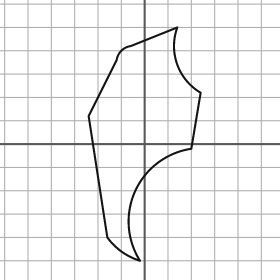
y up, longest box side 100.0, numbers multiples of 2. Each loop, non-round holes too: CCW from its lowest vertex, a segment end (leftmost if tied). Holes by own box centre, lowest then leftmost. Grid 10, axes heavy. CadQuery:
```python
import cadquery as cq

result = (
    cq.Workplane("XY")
    .moveTo(-2.0, -50.0)
    .threePointArc((-4.0, -20.0), (20.0, -2.0))
    .lineTo(24.0, 22.0)
    .threePointArc((14.0, 34.0), (14.0, 50.0))
    .lineTo(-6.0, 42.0)
    .threePointArc((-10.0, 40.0), (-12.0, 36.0))
    .lineTo(-24.0, 12.0)
    .lineTo(-16.0, -40.0)
    .threePointArc((-10.0, -46.0), (-2.0, -50.0))
    .close()
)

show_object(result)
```